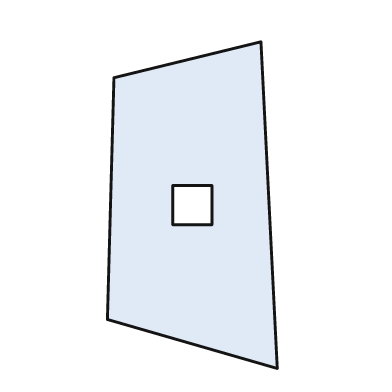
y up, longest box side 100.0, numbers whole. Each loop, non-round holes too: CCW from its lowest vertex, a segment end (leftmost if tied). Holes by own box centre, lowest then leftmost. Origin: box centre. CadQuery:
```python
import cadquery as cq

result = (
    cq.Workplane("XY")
    .moveTo(26.0, -50.0)
    .lineTo(21.0, 50.0)
    .lineTo(-24.0, 39.0)
    .lineTo(-26.0, -35.0)
    .close()
    .moveTo(-6.0, -6.0)
    .lineTo(6.0, -6.0)
    .lineTo(6.0, 6.0)
    .lineTo(-6.0, 6.0)
    .close()
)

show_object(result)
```